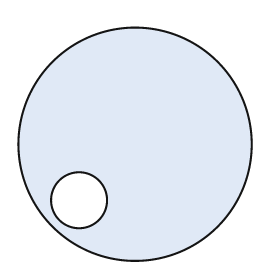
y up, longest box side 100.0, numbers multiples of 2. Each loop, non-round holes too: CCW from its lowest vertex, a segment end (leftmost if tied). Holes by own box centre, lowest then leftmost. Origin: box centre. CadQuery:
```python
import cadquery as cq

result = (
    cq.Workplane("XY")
    .moveTo(0.0, 0.0)
    .circle(50.0)
    .moveTo(-24.0, -24.0)
    .circle(12.0)
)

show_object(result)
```